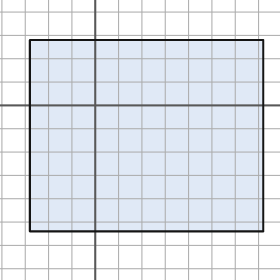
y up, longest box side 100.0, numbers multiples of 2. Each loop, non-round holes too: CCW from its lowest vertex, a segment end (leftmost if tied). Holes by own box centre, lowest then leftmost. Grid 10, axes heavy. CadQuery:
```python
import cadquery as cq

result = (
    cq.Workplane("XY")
    .moveTo(-28.0, -54.0)
    .lineTo(72.0, -54.0)
    .lineTo(72.0, 28.0)
    .lineTo(-28.0, 28.0)
    .close()
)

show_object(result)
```